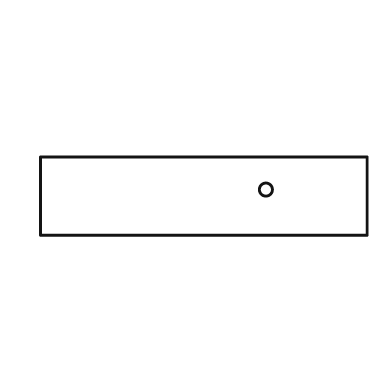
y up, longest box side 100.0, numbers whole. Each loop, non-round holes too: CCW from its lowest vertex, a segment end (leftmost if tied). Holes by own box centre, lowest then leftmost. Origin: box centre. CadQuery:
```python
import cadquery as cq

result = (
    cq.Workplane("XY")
    .moveTo(-50.0, -12.0)
    .lineTo(50.0, -12.0)
    .lineTo(50.0, 12.0)
    .lineTo(-50.0, 12.0)
    .close()
    .moveTo(19.0, 2.0)
    .circle(2.0)
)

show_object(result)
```